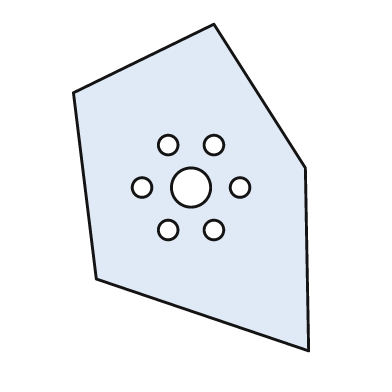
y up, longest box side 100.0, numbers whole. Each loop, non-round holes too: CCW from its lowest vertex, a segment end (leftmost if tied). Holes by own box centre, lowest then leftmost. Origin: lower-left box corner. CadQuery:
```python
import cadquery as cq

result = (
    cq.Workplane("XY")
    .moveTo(72.0, 0.0)
    .lineTo(71.0, 56.0)
    .lineTo(43.0, 100.0)
    .lineTo(0.0, 79.0)
    .lineTo(7.0, 22.0)
    .close()
    .moveTo(29.0, 37.0)
    .circle(3.0)
    .moveTo(43.0, 37.0)
    .circle(3.0)
    .moveTo(21.0, 50.0)
    .circle(3.0)
    .moveTo(36.0, 50.0)
    .circle(6.0)
    .moveTo(51.0, 50.0)
    .circle(3.0)
    .moveTo(29.0, 63.0)
    .circle(3.0)
    .moveTo(43.0, 63.0)
    .circle(3.0)
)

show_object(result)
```